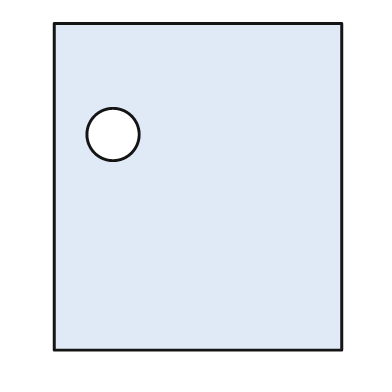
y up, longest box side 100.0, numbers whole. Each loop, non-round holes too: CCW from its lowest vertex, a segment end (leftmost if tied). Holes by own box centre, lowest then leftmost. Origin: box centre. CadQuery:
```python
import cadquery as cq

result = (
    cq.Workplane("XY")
    .moveTo(-44.0, -50.0)
    .lineTo(44.0, -50.0)
    .lineTo(44.0, 50.0)
    .lineTo(-44.0, 50.0)
    .close()
    .moveTo(-26.0, 16.0)
    .circle(8.0)
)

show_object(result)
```